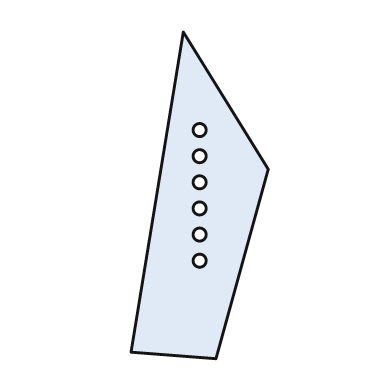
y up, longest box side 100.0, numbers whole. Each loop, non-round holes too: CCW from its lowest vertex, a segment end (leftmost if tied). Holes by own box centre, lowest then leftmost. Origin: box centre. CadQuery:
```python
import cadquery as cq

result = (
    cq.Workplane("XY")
    .moveTo(5.0, -50.0)
    .lineTo(21.0, 8.0)
    .lineTo(-5.0, 50.0)
    .lineTo(-21.0, -48.0)
    .close()
    .moveTo(0.0, -20.0)
    .circle(2.0)
    .moveTo(0.0, -12.0)
    .circle(2.0)
    .moveTo(0.0, -4.0)
    .circle(2.0)
    .moveTo(0.0, 4.0)
    .circle(2.0)
    .moveTo(0.0, 12.0)
    .circle(2.0)
    .moveTo(0.0, 20.0)
    .circle(2.0)
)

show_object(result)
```